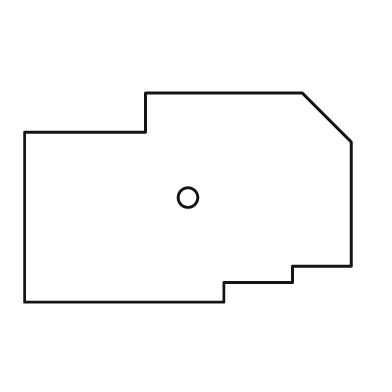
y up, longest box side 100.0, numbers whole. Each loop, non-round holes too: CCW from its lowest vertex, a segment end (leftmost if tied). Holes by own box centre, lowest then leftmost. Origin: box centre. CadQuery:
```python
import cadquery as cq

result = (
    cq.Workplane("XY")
    .moveTo(-50.0, -32.0)
    .lineTo(11.0, -32.0)
    .lineTo(11.0, -26.0)
    .lineTo(32.0, -26.0)
    .lineTo(32.0, -21.0)
    .lineTo(50.0, -21.0)
    .lineTo(50.0, 17.0)
    .lineTo(35.0, 32.0)
    .lineTo(-13.0, 32.0)
    .lineTo(-13.0, 20.0)
    .lineTo(-50.0, 20.0)
    .close()
    .moveTo(0.0, 0.0)
    .circle(3.0)
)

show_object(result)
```